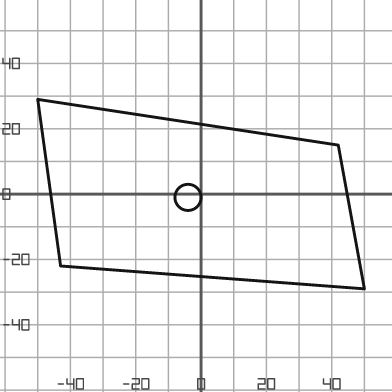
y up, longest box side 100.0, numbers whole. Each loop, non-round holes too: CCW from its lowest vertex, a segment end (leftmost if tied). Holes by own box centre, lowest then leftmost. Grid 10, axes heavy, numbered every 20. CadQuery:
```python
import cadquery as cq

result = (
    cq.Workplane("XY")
    .moveTo(50.0, -29.0)
    .lineTo(42.0, 15.0)
    .lineTo(-50.0, 29.0)
    .lineTo(-43.0, -22.0)
    .close()
    .moveTo(-4.0, -1.0)
    .circle(4.0)
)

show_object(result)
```